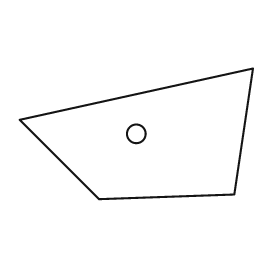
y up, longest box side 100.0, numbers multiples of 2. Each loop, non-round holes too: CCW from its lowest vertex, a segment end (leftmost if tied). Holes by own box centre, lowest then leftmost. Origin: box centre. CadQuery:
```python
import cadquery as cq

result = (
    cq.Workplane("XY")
    .moveTo(-16.0, -28.0)
    .lineTo(42.0, -26.0)
    .lineTo(50.0, 28.0)
    .lineTo(-50.0, 6.0)
    .close()
    .moveTo(0.0, 0.0)
    .circle(4.0)
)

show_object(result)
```